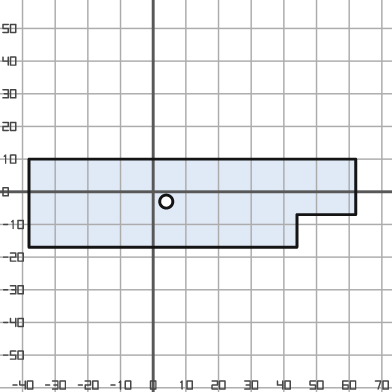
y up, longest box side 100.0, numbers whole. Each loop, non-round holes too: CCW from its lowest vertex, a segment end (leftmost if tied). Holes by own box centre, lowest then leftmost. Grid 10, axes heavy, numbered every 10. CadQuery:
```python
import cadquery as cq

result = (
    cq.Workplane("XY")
    .moveTo(-38.0, -17.0)
    .lineTo(44.0, -17.0)
    .lineTo(44.0, -7.0)
    .lineTo(62.0, -7.0)
    .lineTo(62.0, 10.0)
    .lineTo(-38.0, 10.0)
    .close()
    .moveTo(4.0, -3.0)
    .circle(2.0)
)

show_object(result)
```